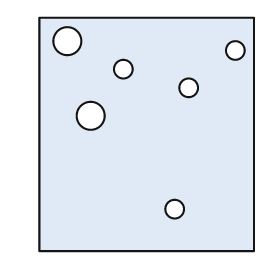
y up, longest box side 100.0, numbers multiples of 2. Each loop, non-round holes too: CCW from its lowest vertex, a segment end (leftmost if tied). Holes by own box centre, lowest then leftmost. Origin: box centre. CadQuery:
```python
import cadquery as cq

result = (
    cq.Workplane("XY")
    .moveTo(-46.0, -50.0)
    .lineTo(46.0, -50.0)
    .lineTo(46.0, 50.0)
    .lineTo(-46.0, 50.0)
    .close()
    .moveTo(12.0, -32.0)
    .circle(4.0)
    .moveTo(-24.0, 8.0)
    .circle(6.0)
    .moveTo(18.0, 20.0)
    .circle(4.0)
    .moveTo(-10.0, 28.0)
    .circle(4.0)
    .moveTo(38.0, 36.0)
    .circle(4.0)
    .moveTo(-34.0, 40.0)
    .circle(6.0)
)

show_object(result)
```